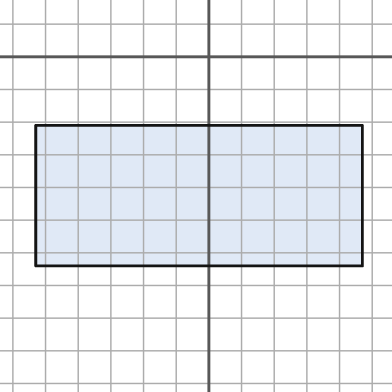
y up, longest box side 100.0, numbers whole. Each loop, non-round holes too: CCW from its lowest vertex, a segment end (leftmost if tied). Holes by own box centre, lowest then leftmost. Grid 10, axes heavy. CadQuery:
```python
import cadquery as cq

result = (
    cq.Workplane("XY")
    .moveTo(-53.0, -64.0)
    .lineTo(47.0, -64.0)
    .lineTo(47.0, -21.0)
    .lineTo(-53.0, -21.0)
    .close()
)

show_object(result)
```